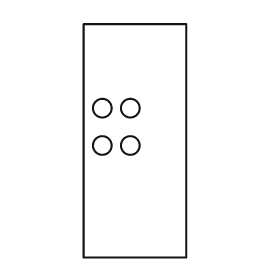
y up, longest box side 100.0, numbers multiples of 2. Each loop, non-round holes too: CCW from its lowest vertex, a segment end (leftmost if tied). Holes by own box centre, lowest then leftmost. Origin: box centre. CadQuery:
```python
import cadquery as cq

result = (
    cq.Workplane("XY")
    .moveTo(-22.0, -50.0)
    .lineTo(22.0, -50.0)
    .lineTo(22.0, 50.0)
    .lineTo(-22.0, 50.0)
    .close()
    .moveTo(-14.0, -2.0)
    .circle(4.0)
    .moveTo(-2.0, -2.0)
    .circle(4.0)
    .moveTo(-14.0, 14.0)
    .circle(4.0)
    .moveTo(-2.0, 14.0)
    .circle(4.0)
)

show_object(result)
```